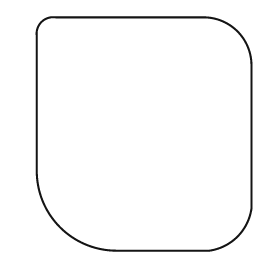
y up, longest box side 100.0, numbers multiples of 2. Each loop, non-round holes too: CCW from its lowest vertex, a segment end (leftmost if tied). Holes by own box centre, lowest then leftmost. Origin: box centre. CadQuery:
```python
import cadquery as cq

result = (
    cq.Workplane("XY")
    .moveTo(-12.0, -50.0)
    .lineTo(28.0, -50.0)
    .threePointArc((40.0, -44.0), (46.0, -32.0))
    .lineTo(46.0, 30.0)
    .threePointArc((40.0, 44.0), (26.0, 50.0))
    .lineTo(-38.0, 50.0)
    .threePointArc((-44.0, 48.0), (-46.0, 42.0))
    .lineTo(-46.0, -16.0)
    .threePointArc((-36.0, -40.0), (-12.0, -50.0))
    .close()
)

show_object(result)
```